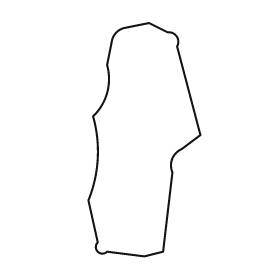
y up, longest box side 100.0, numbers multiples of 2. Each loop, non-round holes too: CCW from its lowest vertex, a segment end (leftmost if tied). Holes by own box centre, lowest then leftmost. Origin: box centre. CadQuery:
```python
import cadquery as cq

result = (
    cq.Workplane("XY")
    .moveTo(0.0, -50.0)
    .lineTo(8.0, -48.0)
    .lineTo(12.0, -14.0)
    .threePointArc((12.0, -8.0), (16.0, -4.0))
    .lineTo(24.0, 2.0)
    .lineTo(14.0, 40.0)
    .threePointArc((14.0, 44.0), (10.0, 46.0))
    .lineTo(2.0, 50.0)
    .lineTo(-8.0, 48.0)
    .threePointArc((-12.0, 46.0), (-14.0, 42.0))
    .lineTo(-16.0, 32.0)
    .threePointArc((-16.0, 20.0), (-22.0, 10.0))
    .threePointArc((-20.0, -8.0), (-24.0, -26.0))
    .lineTo(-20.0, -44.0)
    .threePointArc((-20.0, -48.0), (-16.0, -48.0))
    .close()
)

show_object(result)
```